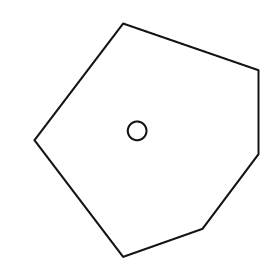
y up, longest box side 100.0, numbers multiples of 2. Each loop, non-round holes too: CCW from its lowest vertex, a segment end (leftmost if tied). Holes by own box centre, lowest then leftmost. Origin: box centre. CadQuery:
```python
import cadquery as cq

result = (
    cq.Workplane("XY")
    .moveTo(-10.0, -50.0)
    .lineTo(24.0, -38.0)
    .lineTo(48.0, -6.0)
    .lineTo(48.0, 30.0)
    .lineTo(-10.0, 50.0)
    .lineTo(-48.0, 0.0)
    .close()
    .moveTo(-4.0, 4.0)
    .circle(4.0)
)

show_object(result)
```